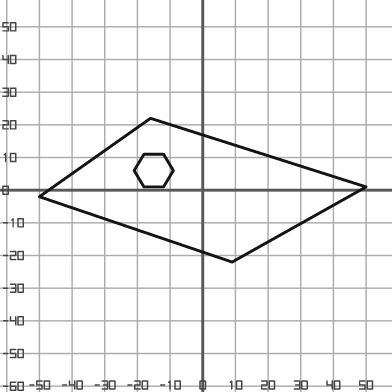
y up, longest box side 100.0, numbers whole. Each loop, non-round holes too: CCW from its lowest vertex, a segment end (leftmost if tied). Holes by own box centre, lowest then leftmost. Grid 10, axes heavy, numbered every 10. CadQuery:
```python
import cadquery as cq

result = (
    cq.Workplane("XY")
    .moveTo(9.0, -22.0)
    .lineTo(50.0, 1.0)
    .lineTo(-16.0, 22.0)
    .lineTo(-50.0, -2.0)
    .close()
    .moveTo(-18.0, 1.0)
    .lineTo(-12.0, 1.0)
    .lineTo(-9.0, 6.0)
    .lineTo(-12.0, 11.0)
    .lineTo(-18.0, 11.0)
    .lineTo(-21.0, 6.0)
    .close()
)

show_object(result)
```